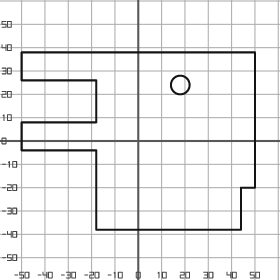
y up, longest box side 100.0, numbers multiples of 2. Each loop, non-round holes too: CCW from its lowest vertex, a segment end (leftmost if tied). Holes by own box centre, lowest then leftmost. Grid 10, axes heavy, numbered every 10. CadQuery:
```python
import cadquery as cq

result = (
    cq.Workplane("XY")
    .moveTo(-18.0, -38.0)
    .lineTo(44.0, -38.0)
    .lineTo(44.0, -20.0)
    .lineTo(50.0, -20.0)
    .lineTo(50.0, 38.0)
    .lineTo(-50.0, 38.0)
    .lineTo(-50.0, 26.0)
    .lineTo(-18.0, 26.0)
    .lineTo(-18.0, 8.0)
    .lineTo(-50.0, 8.0)
    .lineTo(-50.0, -4.0)
    .lineTo(-18.0, -4.0)
    .close()
    .moveTo(18.0, 24.0)
    .circle(4.0)
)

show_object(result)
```